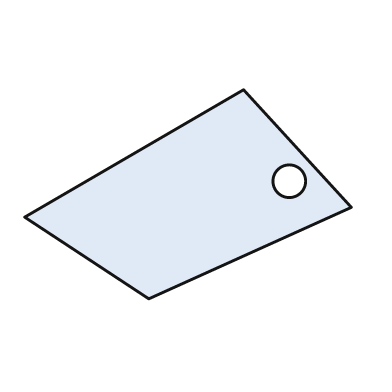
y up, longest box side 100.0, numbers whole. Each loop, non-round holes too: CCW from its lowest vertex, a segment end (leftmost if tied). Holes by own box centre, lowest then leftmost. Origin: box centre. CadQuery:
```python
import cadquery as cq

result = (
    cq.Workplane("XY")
    .moveTo(-12.0, -32.0)
    .lineTo(50.0, -4.0)
    .lineTo(17.0, 32.0)
    .lineTo(-50.0, -7.0)
    .close()
    .moveTo(31.0, 4.0)
    .circle(5.0)
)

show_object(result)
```